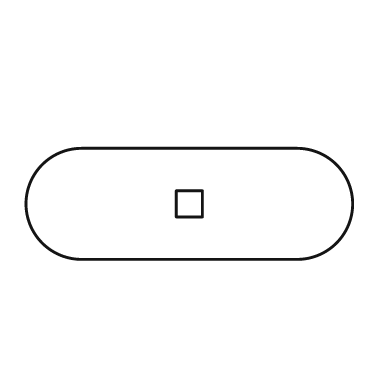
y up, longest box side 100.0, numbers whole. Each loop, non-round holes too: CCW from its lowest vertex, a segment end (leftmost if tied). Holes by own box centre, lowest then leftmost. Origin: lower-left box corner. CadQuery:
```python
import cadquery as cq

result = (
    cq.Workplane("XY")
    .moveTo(17.0, 0.0)
    .lineTo(83.0, 0.0)
    .threePointArc((100.0, 17.0), (83.0, 34.0))
    .lineTo(17.0, 34.0)
    .threePointArc((0.0, 17.0), (17.0, 0.0))
    .close()
    .moveTo(46.0, 13.0)
    .lineTo(54.0, 13.0)
    .lineTo(54.0, 21.0)
    .lineTo(46.0, 21.0)
    .close()
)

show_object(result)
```